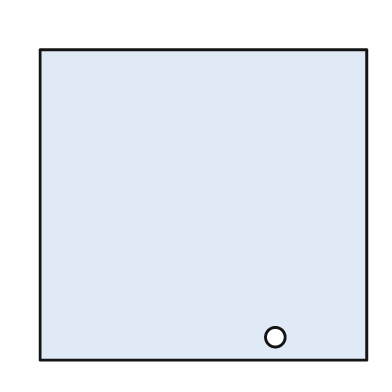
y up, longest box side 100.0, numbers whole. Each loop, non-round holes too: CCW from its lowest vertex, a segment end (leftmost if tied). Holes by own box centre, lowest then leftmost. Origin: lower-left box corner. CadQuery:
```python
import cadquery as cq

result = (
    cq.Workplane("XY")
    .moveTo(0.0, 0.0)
    .lineTo(100.0, 0.0)
    .lineTo(100.0, 95.0)
    .lineTo(0.0, 95.0)
    .close()
    .moveTo(72.0, 7.0)
    .circle(3.0)
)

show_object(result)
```